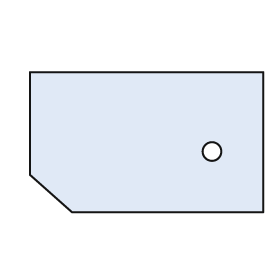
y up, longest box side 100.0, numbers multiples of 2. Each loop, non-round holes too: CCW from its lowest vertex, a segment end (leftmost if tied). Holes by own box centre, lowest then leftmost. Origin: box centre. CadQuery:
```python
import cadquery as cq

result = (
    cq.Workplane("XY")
    .moveTo(-32.0, -30.0)
    .lineTo(50.0, -30.0)
    .lineTo(50.0, 30.0)
    .lineTo(-50.0, 30.0)
    .lineTo(-50.0, -14.0)
    .close()
    .moveTo(28.0, -4.0)
    .circle(4.0)
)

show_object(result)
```